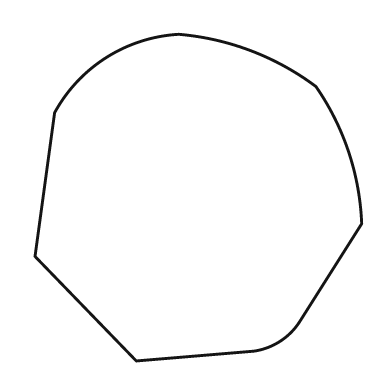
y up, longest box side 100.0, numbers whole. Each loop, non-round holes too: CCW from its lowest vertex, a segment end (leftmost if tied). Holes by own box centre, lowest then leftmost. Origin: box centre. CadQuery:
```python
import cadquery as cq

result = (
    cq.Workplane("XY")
    .moveTo(-19.0, -50.0)
    .lineTo(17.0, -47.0)
    .threePointArc((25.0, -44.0), (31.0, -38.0))
    .lineTo(50.0, -8.0)
    .threePointArc((46.0, 14.0), (36.0, 34.0))
    .threePointArc((16.0, 45.0), (-6.0, 50.0))
    .threePointArc((-28.0, 43.0), (-44.0, 26.0))
    .lineTo(-50.0, -18.0)
    .close()
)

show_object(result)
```